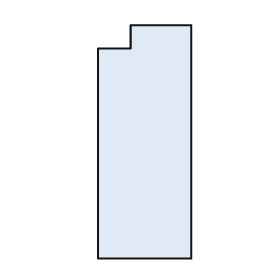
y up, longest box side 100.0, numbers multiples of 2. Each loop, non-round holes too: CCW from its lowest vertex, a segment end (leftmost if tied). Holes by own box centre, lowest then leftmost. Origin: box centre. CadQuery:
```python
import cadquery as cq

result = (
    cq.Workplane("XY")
    .moveTo(-20.0, -50.0)
    .lineTo(20.0, -50.0)
    .lineTo(20.0, 50.0)
    .lineTo(-6.0, 50.0)
    .lineTo(-6.0, 40.0)
    .lineTo(-20.0, 40.0)
    .close()
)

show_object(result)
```